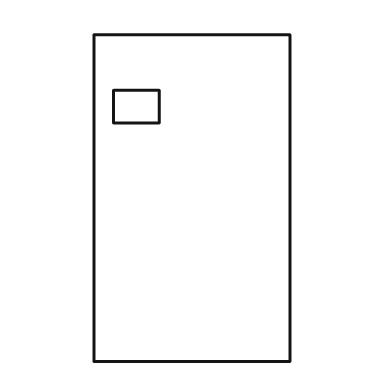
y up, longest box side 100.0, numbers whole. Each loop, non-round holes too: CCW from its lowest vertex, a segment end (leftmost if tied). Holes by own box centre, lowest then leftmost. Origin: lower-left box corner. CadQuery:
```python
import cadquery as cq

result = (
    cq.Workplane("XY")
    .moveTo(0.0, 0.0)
    .lineTo(60.0, 0.0)
    .lineTo(60.0, 100.0)
    .lineTo(0.0, 100.0)
    .close()
    .moveTo(6.0, 73.0)
    .lineTo(20.0, 73.0)
    .lineTo(20.0, 83.0)
    .lineTo(6.0, 83.0)
    .close()
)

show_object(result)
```